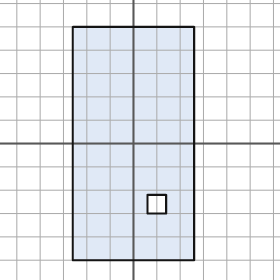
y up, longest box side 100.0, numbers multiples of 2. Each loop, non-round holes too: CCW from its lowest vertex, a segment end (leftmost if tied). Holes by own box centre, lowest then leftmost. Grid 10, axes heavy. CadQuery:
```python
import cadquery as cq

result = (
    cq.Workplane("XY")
    .moveTo(-26.0, -50.0)
    .lineTo(26.0, -50.0)
    .lineTo(26.0, 50.0)
    .lineTo(-26.0, 50.0)
    .close()
    .moveTo(6.0, -30.0)
    .lineTo(14.0, -30.0)
    .lineTo(14.0, -22.0)
    .lineTo(6.0, -22.0)
    .close()
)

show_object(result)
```